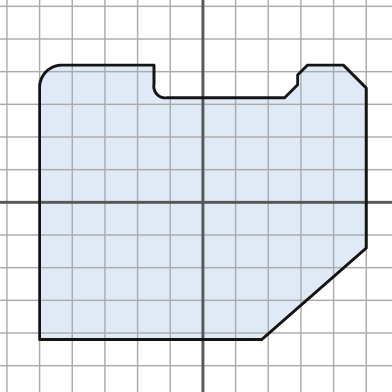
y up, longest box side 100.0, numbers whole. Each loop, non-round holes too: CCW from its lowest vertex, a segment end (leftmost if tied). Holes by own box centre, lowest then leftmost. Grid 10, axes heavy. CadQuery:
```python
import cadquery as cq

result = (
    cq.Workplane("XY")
    .moveTo(-50.0, -42.0)
    .lineTo(18.0, -42.0)
    .lineTo(50.0, -14.0)
    .lineTo(50.0, 35.0)
    .lineTo(43.0, 42.0)
    .lineTo(32.0, 42.0)
    .lineTo(29.0, 39.0)
    .lineTo(29.0, 36.0)
    .lineTo(25.0, 32.0)
    .lineTo(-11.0, 32.0)
    .threePointArc((-14.0, 33.0), (-15.0, 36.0))
    .lineTo(-15.0, 42.0)
    .lineTo(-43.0, 42.0)
    .threePointArc((-48.0, 40.0), (-50.0, 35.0))
    .close()
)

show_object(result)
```